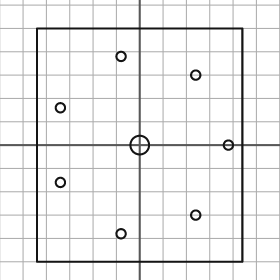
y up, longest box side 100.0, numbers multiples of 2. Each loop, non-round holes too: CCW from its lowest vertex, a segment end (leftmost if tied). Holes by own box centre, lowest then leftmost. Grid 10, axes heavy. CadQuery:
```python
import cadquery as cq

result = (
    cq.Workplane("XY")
    .moveTo(-44.0, -50.0)
    .lineTo(44.0, -50.0)
    .lineTo(44.0, 50.0)
    .lineTo(-44.0, 50.0)
    .close()
    .moveTo(-8.0, -38.0)
    .circle(2.0)
    .moveTo(24.0, -30.0)
    .circle(2.0)
    .moveTo(-34.0, -16.0)
    .circle(2.0)
    .moveTo(0.0, 0.0)
    .circle(4.0)
    .moveTo(38.0, 0.0)
    .circle(2.0)
    .moveTo(-34.0, 16.0)
    .circle(2.0)
    .moveTo(24.0, 30.0)
    .circle(2.0)
    .moveTo(-8.0, 38.0)
    .circle(2.0)
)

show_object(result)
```